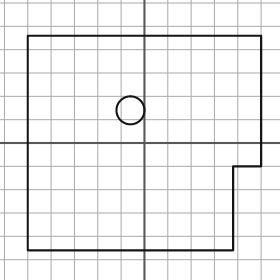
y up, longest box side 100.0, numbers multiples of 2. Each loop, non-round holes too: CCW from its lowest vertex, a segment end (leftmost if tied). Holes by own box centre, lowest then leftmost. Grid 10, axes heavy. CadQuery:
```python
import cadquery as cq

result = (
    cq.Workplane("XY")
    .moveTo(-50.0, -46.0)
    .lineTo(38.0, -46.0)
    .lineTo(38.0, -10.0)
    .lineTo(50.0, -10.0)
    .lineTo(50.0, 46.0)
    .lineTo(-50.0, 46.0)
    .close()
    .moveTo(-6.0, 14.0)
    .circle(6.0)
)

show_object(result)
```